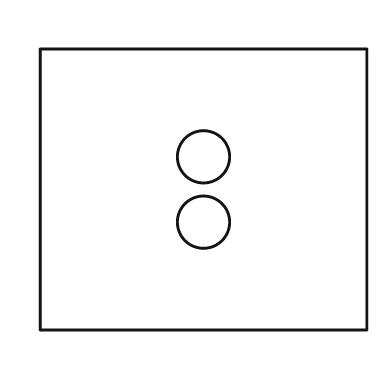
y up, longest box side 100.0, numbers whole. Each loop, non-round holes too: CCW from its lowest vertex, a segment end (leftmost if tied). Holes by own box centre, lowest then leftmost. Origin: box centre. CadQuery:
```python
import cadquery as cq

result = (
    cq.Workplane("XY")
    .moveTo(-50.0, -43.0)
    .lineTo(50.0, -43.0)
    .lineTo(50.0, 43.0)
    .lineTo(-50.0, 43.0)
    .close()
    .moveTo(0.0, -10.0)
    .circle(8.0)
    .moveTo(0.0, 10.0)
    .circle(8.0)
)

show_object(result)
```